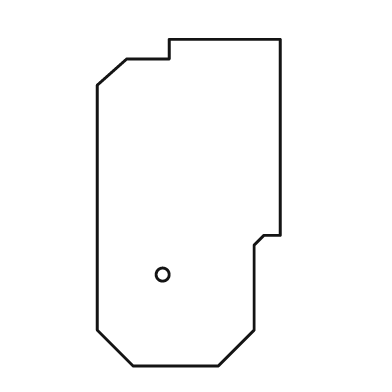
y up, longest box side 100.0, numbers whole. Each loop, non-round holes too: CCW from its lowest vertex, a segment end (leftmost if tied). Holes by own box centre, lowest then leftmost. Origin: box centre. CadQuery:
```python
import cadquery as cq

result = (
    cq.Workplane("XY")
    .moveTo(-17.0, -50.0)
    .lineTo(9.0, -50.0)
    .lineTo(20.0, -39.0)
    .lineTo(20.0, -13.0)
    .lineTo(23.0, -10.0)
    .lineTo(28.0, -10.0)
    .lineTo(28.0, 50.0)
    .lineTo(-6.0, 50.0)
    .lineTo(-6.0, 44.0)
    .lineTo(-19.0, 44.0)
    .lineTo(-28.0, 36.0)
    .lineTo(-28.0, -39.0)
    .close()
    .moveTo(-8.0, -22.0)
    .circle(2.0)
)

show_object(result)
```